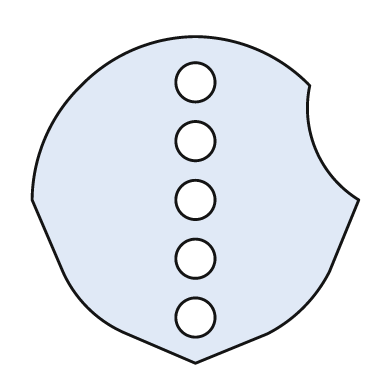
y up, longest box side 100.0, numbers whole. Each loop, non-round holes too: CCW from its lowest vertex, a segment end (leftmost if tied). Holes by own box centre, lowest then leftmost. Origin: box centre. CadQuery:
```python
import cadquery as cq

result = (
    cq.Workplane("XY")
    .moveTo(0.0, -50.0)
    .lineTo(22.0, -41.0)
    .threePointArc((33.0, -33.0), (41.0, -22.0))
    .lineTo(50.0, 0.0)
    .threePointArc((37.0, 15.0), (35.0, 35.0))
    .threePointArc((19.0, 46.0), (0.0, 50.0))
    .threePointArc((-19.0, 46.0), (-35.0, 35.0))
    .threePointArc((-46.0, 19.0), (-50.0, 0.0))
    .lineTo(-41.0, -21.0)
    .threePointArc((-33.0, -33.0), (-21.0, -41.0))
    .close()
    .moveTo(0.0, -36.0)
    .circle(6.0)
    .moveTo(0.0, -18.0)
    .circle(6.0)
    .moveTo(0.0, 0.0)
    .circle(6.0)
    .moveTo(0.0, 18.0)
    .circle(6.0)
    .moveTo(0.0, 36.0)
    .circle(6.0)
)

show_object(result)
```